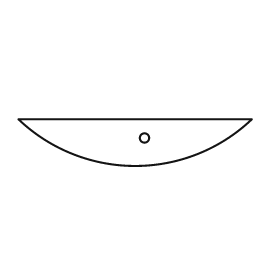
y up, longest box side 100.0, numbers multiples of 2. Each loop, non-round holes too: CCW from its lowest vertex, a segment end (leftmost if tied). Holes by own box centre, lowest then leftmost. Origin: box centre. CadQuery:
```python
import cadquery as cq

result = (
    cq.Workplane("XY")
    .moveTo(-50.0, 10.0)
    .threePointArc((0.0, -10.0), (50.0, 10.0))
    .close()
    .moveTo(4.0, 2.0)
    .circle(2.0)
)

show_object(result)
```